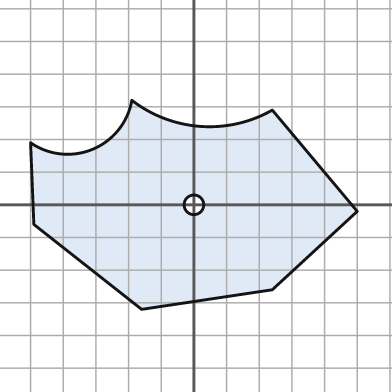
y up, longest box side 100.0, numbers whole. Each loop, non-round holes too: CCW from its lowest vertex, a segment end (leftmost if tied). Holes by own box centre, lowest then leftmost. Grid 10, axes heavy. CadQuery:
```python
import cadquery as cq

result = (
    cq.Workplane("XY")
    .moveTo(-16.0, -32.0)
    .lineTo(24.0, -26.0)
    .lineTo(50.0, -2.0)
    .lineTo(24.0, 29.0)
    .threePointArc((2.0, 24.0), (-19.0, 32.0))
    .threePointArc((-31.0, 17.0), (-50.0, 19.0))
    .lineTo(-49.0, -6.0)
    .close()
    .moveTo(0.0, 0.0)
    .circle(3.0)
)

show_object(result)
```